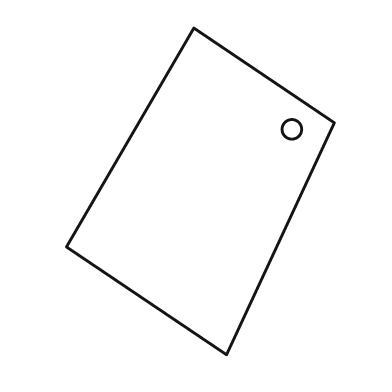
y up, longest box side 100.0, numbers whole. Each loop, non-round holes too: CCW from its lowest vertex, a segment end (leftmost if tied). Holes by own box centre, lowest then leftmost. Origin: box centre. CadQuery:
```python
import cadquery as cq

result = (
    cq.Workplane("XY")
    .moveTo(8.0, -50.0)
    .lineTo(41.0, 21.0)
    .lineTo(-2.0, 50.0)
    .lineTo(-41.0, -17.0)
    .close()
    .moveTo(28.0, 19.0)
    .circle(3.0)
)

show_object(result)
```